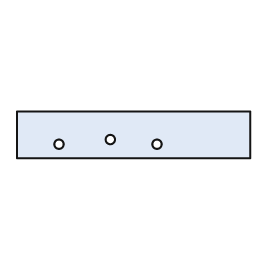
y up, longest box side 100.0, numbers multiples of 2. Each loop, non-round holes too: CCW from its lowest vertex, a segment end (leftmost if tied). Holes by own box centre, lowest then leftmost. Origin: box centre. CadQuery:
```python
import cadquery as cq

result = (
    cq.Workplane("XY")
    .moveTo(-50.0, -10.0)
    .lineTo(50.0, -10.0)
    .lineTo(50.0, 10.0)
    .lineTo(-50.0, 10.0)
    .close()
    .moveTo(-32.0, -4.0)
    .circle(2.0)
    .moveTo(10.0, -4.0)
    .circle(2.0)
    .moveTo(-10.0, -2.0)
    .circle(2.0)
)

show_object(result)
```